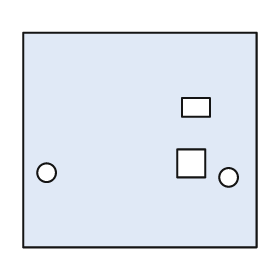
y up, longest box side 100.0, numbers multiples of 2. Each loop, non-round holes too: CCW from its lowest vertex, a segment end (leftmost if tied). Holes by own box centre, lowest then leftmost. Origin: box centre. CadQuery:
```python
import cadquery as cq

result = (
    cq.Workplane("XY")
    .moveTo(-50.0, -46.0)
    .lineTo(50.0, -46.0)
    .lineTo(50.0, 46.0)
    .lineTo(-50.0, 46.0)
    .close()
    .moveTo(38.0, -16.0)
    .circle(4.0)
    .moveTo(-40.0, -14.0)
    .circle(4.0)
    .moveTo(16.0, -16.0)
    .lineTo(28.0, -16.0)
    .lineTo(28.0, -4.0)
    .lineTo(16.0, -4.0)
    .close()
    .moveTo(18.0, 10.0)
    .lineTo(30.0, 10.0)
    .lineTo(30.0, 18.0)
    .lineTo(18.0, 18.0)
    .close()
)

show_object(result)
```